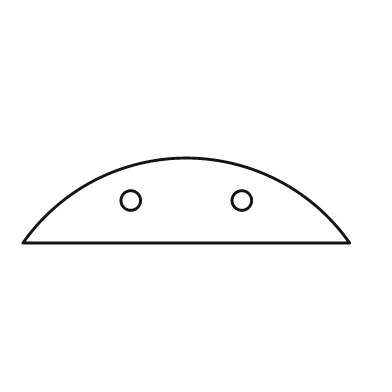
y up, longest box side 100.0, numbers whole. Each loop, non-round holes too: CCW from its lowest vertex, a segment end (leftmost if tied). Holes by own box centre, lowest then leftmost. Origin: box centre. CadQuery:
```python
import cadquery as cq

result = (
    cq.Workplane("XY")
    .moveTo(-50.0, -13.0)
    .lineTo(50.0, -13.0)
    .threePointArc((0.0, 13.0), (-50.0, -13.0))
    .close()
    .moveTo(-17.0, 0.0)
    .circle(3.0)
    .moveTo(17.0, 0.0)
    .circle(3.0)
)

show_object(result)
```